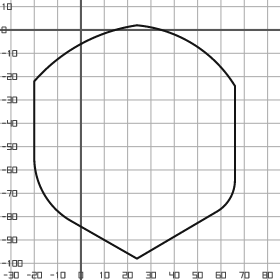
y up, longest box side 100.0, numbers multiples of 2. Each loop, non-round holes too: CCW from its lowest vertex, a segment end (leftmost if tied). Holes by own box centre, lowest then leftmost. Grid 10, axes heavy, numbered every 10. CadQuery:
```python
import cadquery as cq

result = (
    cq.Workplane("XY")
    .moveTo(24.0, -98.0)
    .lineTo(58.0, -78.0)
    .threePointArc((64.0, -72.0), (66.0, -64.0))
    .lineTo(66.0, -24.0)
    .threePointArc((48.0, -6.0), (24.0, 2.0))
    .threePointArc((0.0, -6.0), (-20.0, -22.0))
    .lineTo(-20.0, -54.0)
    .threePointArc((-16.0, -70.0), (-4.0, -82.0))
    .close()
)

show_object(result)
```